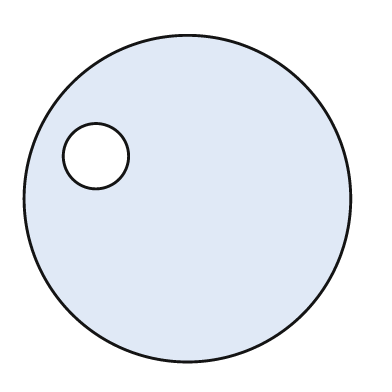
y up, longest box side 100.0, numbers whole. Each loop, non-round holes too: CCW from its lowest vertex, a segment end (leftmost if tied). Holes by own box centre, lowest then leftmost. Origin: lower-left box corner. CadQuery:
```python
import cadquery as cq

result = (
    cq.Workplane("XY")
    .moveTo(50.0, 50.0)
    .circle(50.0)
    .moveTo(22.0, 63.0)
    .circle(10.0)
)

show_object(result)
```